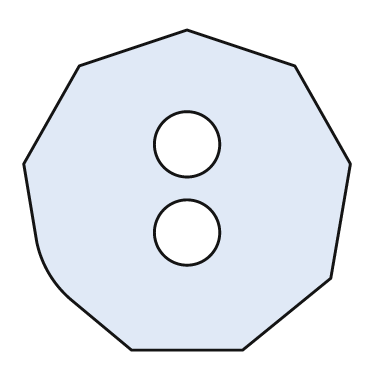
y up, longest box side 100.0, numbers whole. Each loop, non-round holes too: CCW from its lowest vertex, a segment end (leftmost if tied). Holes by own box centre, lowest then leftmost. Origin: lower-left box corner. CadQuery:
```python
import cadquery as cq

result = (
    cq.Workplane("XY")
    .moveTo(33.0, 0.0)
    .lineTo(67.0, 0.0)
    .lineTo(94.0, 22.0)
    .lineTo(100.0, 57.0)
    .lineTo(83.0, 87.0)
    .lineTo(50.0, 98.0)
    .lineTo(17.0, 87.0)
    .lineTo(0.0, 57.0)
    .lineTo(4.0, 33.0)
    .threePointArc((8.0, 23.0), (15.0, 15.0))
    .close()
    .moveTo(50.0, 36.0)
    .circle(10.0)
    .moveTo(50.0, 63.0)
    .circle(10.0)
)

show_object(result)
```